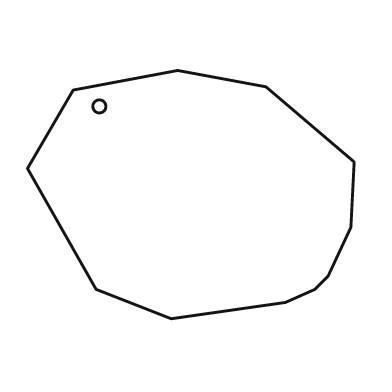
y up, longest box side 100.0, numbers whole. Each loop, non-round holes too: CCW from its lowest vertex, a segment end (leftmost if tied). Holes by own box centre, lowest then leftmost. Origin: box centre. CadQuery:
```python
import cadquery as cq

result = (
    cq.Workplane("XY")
    .moveTo(-6.0, -38.0)
    .lineTo(29.0, -33.0)
    .lineTo(38.0, -29.0)
    .lineTo(42.0, -25.0)
    .lineTo(49.0, -10.0)
    .lineTo(50.0, 10.0)
    .lineTo(23.0, 33.0)
    .lineTo(-4.0, 38.0)
    .lineTo(-36.0, 32.0)
    .lineTo(-50.0, 8.0)
    .lineTo(-29.0, -29.0)
    .close()
    .moveTo(-28.0, 27.0)
    .circle(2.0)
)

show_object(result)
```